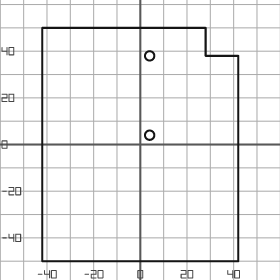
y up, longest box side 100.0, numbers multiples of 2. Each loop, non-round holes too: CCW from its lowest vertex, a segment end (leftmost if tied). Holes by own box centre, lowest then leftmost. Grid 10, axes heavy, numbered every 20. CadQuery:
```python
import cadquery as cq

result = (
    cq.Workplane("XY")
    .moveTo(-42.0, -50.0)
    .lineTo(42.0, -50.0)
    .lineTo(42.0, 38.0)
    .lineTo(28.0, 38.0)
    .lineTo(28.0, 50.0)
    .lineTo(-42.0, 50.0)
    .close()
    .moveTo(4.0, 4.0)
    .circle(2.0)
    .moveTo(4.0, 38.0)
    .circle(2.0)
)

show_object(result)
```